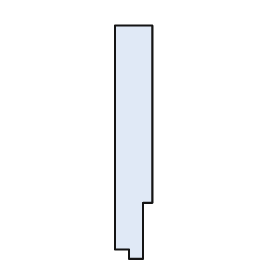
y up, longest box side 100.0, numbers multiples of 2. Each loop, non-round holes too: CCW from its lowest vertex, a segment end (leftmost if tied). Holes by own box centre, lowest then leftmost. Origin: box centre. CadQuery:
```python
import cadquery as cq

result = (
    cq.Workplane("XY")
    .moveTo(-2.0, -50.0)
    .lineTo(4.0, -50.0)
    .lineTo(4.0, -26.0)
    .lineTo(8.0, -26.0)
    .lineTo(8.0, 50.0)
    .lineTo(-8.0, 50.0)
    .lineTo(-8.0, -46.0)
    .lineTo(-2.0, -46.0)
    .close()
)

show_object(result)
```